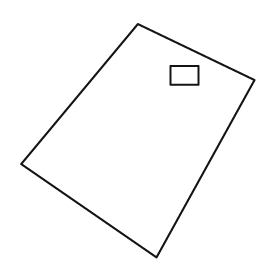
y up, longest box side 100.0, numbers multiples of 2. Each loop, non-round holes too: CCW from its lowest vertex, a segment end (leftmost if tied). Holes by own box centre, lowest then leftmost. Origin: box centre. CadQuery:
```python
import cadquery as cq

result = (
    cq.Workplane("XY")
    .moveTo(8.0, -50.0)
    .lineTo(50.0, 26.0)
    .lineTo(0.0, 50.0)
    .lineTo(-50.0, -10.0)
    .close()
    .moveTo(14.0, 24.0)
    .lineTo(26.0, 24.0)
    .lineTo(26.0, 32.0)
    .lineTo(14.0, 32.0)
    .close()
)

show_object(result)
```